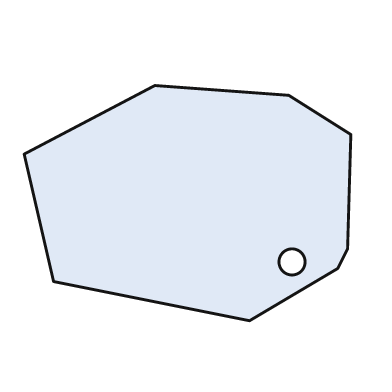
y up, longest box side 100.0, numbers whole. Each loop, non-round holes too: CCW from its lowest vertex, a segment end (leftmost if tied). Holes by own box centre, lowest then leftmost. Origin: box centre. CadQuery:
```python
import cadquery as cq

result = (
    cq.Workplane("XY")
    .moveTo(19.0, -36.0)
    .lineTo(46.0, -20.0)
    .lineTo(49.0, -14.0)
    .lineTo(50.0, 21.0)
    .lineTo(31.0, 33.0)
    .lineTo(-10.0, 36.0)
    .lineTo(-50.0, 15.0)
    .lineTo(-41.0, -24.0)
    .close()
    .moveTo(32.0, -18.0)
    .circle(4.0)
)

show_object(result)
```